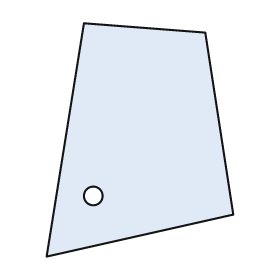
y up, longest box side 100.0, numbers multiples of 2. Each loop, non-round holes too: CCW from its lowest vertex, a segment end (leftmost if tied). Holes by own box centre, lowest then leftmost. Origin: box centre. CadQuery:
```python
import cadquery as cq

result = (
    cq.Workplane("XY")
    .moveTo(-40.0, -50.0)
    .lineTo(40.0, -32.0)
    .lineTo(28.0, 46.0)
    .lineTo(-24.0, 50.0)
    .close()
    .moveTo(-20.0, -24.0)
    .circle(4.0)
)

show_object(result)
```